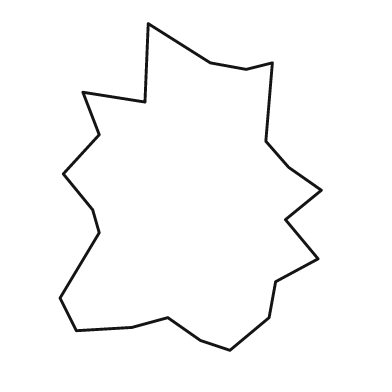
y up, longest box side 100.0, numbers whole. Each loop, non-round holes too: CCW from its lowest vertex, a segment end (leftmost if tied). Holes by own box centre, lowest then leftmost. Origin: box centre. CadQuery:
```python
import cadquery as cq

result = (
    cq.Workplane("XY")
    .moveTo(12.0, -50.0)
    .lineTo(24.0, -40.0)
    .lineTo(26.0, -29.0)
    .lineTo(39.0, -22.0)
    .lineTo(29.0, -10.0)
    .lineTo(40.0, -1.0)
    .lineTo(30.0, 6.0)
    .lineTo(23.0, 14.0)
    .lineTo(25.0, 38.0)
    .lineTo(17.0, 36.0)
    .lineTo(6.0, 38.0)
    .lineTo(-13.0, 50.0)
    .lineTo(-14.0, 26.0)
    .lineTo(-33.0, 29.0)
    .lineTo(-28.0, 16.0)
    .lineTo(-39.0, 4.0)
    .lineTo(-30.0, -7.0)
    .lineTo(-28.0, -14.0)
    .lineTo(-40.0, -34.0)
    .lineTo(-35.0, -44.0)
    .lineTo(-18.0, -43.0)
    .lineTo(-7.0, -40.0)
    .lineTo(3.0, -47.0)
    .close()
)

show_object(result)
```